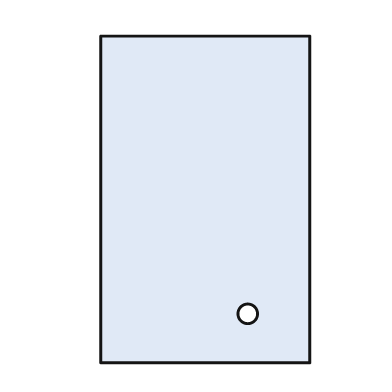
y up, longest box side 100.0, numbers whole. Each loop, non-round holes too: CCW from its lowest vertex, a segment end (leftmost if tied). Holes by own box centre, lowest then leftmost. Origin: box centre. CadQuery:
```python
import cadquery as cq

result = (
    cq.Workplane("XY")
    .moveTo(-32.0, -50.0)
    .lineTo(32.0, -50.0)
    .lineTo(32.0, 50.0)
    .lineTo(-32.0, 50.0)
    .close()
    .moveTo(13.0, -35.0)
    .circle(3.0)
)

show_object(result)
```